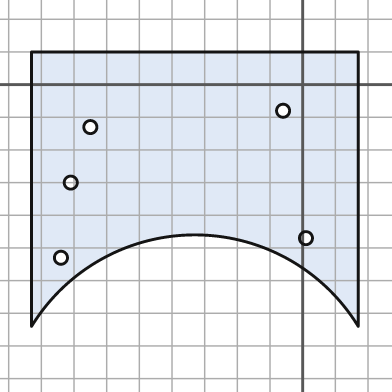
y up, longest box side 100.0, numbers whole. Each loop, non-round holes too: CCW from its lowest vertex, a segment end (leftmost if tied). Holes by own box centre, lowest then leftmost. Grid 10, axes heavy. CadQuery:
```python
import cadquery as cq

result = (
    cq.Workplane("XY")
    .moveTo(-83.0, -74.0)
    .threePointArc((-33.0, -46.0), (17.0, -74.0))
    .lineTo(17.0, 10.0)
    .lineTo(-83.0, 10.0)
    .close()
    .moveTo(-74.0, -53.0)
    .circle(2.0)
    .moveTo(1.0, -47.0)
    .circle(2.0)
    .moveTo(-71.0, -30.0)
    .circle(2.0)
    .moveTo(-65.0, -13.0)
    .circle(2.0)
    .moveTo(-6.0, -8.0)
    .circle(2.0)
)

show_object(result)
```